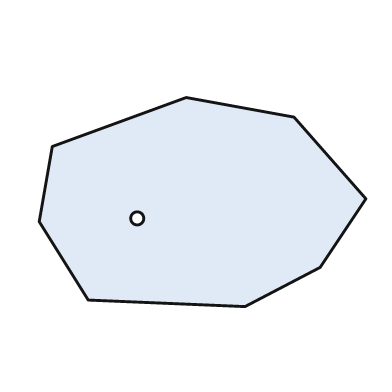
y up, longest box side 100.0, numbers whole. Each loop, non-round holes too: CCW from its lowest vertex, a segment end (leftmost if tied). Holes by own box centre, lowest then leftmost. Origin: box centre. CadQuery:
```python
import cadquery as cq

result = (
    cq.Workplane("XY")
    .moveTo(13.0, -32.0)
    .lineTo(36.0, -20.0)
    .lineTo(50.0, 1.0)
    .lineTo(28.0, 26.0)
    .lineTo(-5.0, 32.0)
    .lineTo(-46.0, 17.0)
    .lineTo(-50.0, -6.0)
    .lineTo(-35.0, -30.0)
    .close()
    .moveTo(-20.0, -5.0)
    .circle(2.0)
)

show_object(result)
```